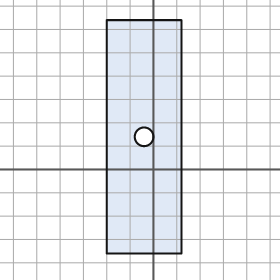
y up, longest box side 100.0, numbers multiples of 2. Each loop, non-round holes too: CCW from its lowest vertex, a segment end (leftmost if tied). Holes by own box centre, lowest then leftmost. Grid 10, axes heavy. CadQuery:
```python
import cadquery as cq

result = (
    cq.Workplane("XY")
    .moveTo(-20.0, -36.0)
    .lineTo(12.0, -36.0)
    .lineTo(12.0, 64.0)
    .lineTo(-20.0, 64.0)
    .close()
    .moveTo(-4.0, 14.0)
    .circle(4.0)
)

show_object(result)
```